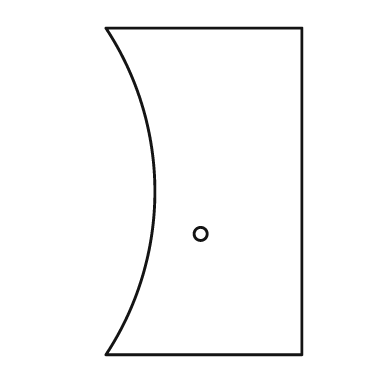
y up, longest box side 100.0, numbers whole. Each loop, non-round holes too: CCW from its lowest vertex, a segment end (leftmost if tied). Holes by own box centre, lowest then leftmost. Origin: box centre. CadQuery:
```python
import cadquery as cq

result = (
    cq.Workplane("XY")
    .moveTo(-30.0, -50.0)
    .lineTo(30.0, -50.0)
    .lineTo(30.0, 50.0)
    .lineTo(-30.0, 50.0)
    .threePointArc((-15.0, 0.0), (-30.0, -50.0))
    .close()
    .moveTo(-1.0, -13.0)
    .circle(2.0)
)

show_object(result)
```